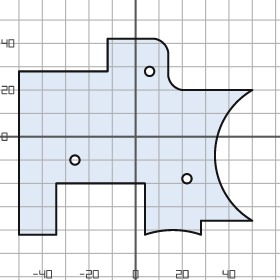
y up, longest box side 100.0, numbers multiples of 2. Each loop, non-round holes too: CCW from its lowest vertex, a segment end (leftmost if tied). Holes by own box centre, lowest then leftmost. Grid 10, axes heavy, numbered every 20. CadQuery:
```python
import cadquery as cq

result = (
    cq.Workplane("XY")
    .moveTo(-50.0, -42.0)
    .lineTo(-34.0, -42.0)
    .lineTo(-34.0, -20.0)
    .lineTo(4.0, -20.0)
    .lineTo(4.0, -42.0)
    .threePointArc((16.0, -40.0), (28.0, -42.0))
    .lineTo(28.0, -36.0)
    .lineTo(50.0, -36.0)
    .threePointArc((34.0, -8.0), (50.0, 20.0))
    .lineTo(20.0, 20.0)
    .threePointArc((16.0, 22.0), (14.0, 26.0))
    .lineTo(14.0, 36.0)
    .threePointArc((12.0, 40.0), (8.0, 42.0))
    .lineTo(-12.0, 42.0)
    .lineTo(-12.0, 28.0)
    .lineTo(-50.0, 28.0)
    .close()
    .moveTo(22.0, -18.0)
    .circle(2.0)
    .moveTo(-26.0, -10.0)
    .circle(2.0)
    .moveTo(6.0, 28.0)
    .circle(2.0)
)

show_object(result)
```